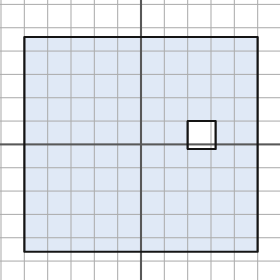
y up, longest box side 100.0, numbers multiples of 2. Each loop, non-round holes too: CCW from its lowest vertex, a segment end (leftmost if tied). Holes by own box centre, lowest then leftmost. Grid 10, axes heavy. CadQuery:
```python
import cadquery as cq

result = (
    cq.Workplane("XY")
    .moveTo(-50.0, -46.0)
    .lineTo(50.0, -46.0)
    .lineTo(50.0, 46.0)
    .lineTo(-50.0, 46.0)
    .close()
    .moveTo(20.0, -2.0)
    .lineTo(32.0, -2.0)
    .lineTo(32.0, 10.0)
    .lineTo(20.0, 10.0)
    .close()
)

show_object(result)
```